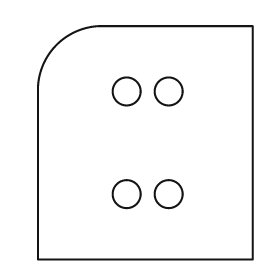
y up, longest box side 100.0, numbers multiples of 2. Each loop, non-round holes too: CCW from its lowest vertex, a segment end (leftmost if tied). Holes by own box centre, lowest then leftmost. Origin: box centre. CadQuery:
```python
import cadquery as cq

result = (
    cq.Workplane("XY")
    .moveTo(-46.0, -50.0)
    .lineTo(46.0, -50.0)
    .lineTo(46.0, 50.0)
    .lineTo(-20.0, 50.0)
    .threePointArc((-38.0, 42.0), (-46.0, 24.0))
    .close()
    .moveTo(-8.0, -22.0)
    .circle(6.0)
    .moveTo(10.0, -22.0)
    .circle(6.0)
    .moveTo(-8.0, 22.0)
    .circle(6.0)
    .moveTo(10.0, 22.0)
    .circle(6.0)
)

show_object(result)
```